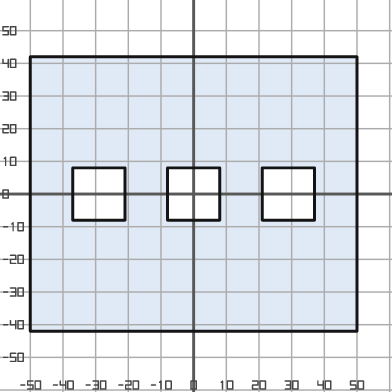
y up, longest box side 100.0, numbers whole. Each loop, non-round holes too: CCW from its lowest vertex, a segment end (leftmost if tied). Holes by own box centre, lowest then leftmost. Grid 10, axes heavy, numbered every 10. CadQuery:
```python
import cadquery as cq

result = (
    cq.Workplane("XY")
    .moveTo(-50.0, -42.0)
    .lineTo(50.0, -42.0)
    .lineTo(50.0, 42.0)
    .lineTo(-50.0, 42.0)
    .close()
    .moveTo(-37.0, -8.0)
    .lineTo(-21.0, -8.0)
    .lineTo(-21.0, 8.0)
    .lineTo(-37.0, 8.0)
    .close()
    .moveTo(-8.0, -8.0)
    .lineTo(8.0, -8.0)
    .lineTo(8.0, 8.0)
    .lineTo(-8.0, 8.0)
    .close()
    .moveTo(21.0, -8.0)
    .lineTo(37.0, -8.0)
    .lineTo(37.0, 8.0)
    .lineTo(21.0, 8.0)
    .close()
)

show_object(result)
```